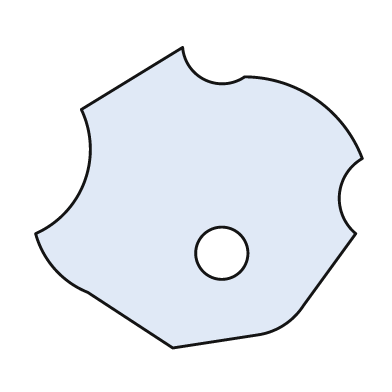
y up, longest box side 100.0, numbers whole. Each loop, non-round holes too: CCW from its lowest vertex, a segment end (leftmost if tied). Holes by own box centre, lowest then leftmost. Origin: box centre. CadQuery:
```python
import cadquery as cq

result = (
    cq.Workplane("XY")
    .moveTo(-8.0, -46.0)
    .lineTo(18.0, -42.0)
    .threePointArc((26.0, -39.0), (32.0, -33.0))
    .lineTo(48.0, -11.0)
    .threePointArc((43.0, 1.0), (50.0, 12.0))
    .threePointArc((36.0, 30.0), (14.0, 37.0))
    .threePointArc((2.0, 36.0), (-5.0, 46.0))
    .lineTo(-36.0, 27.0)
    .threePointArc((-35.0, 5.0), (-50.0, -11.0))
    .threePointArc((-44.0, -22.0), (-34.0, -29.0))
    .close()
    .moveTo(7.0, -17.0)
    .circle(8.0)
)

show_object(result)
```